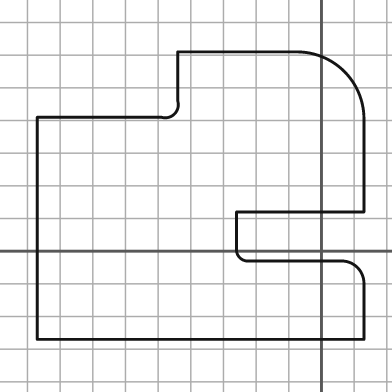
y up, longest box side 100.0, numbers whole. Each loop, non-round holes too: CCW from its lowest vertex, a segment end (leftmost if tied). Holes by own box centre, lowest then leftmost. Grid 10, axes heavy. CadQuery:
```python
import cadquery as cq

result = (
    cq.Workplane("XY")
    .moveTo(-87.0, -27.0)
    .lineTo(13.0, -27.0)
    .lineTo(13.0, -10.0)
    .threePointArc((11.0, -5.0), (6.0, -3.0))
    .lineTo(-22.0, -3.0)
    .threePointArc((-25.0, -2.0), (-26.0, 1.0))
    .lineTo(-26.0, 12.0)
    .lineTo(13.0, 12.0)
    .lineTo(13.0, 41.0)
    .threePointArc((7.0, 55.0), (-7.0, 61.0))
    .lineTo(-44.0, 61.0)
    .lineTo(-44.0, 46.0)
    .threePointArc((-45.0, 42.0), (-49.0, 41.0))
    .lineTo(-87.0, 41.0)
    .close()
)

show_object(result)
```